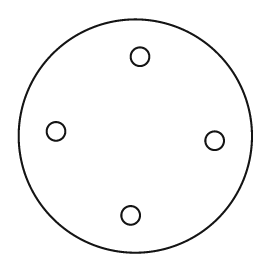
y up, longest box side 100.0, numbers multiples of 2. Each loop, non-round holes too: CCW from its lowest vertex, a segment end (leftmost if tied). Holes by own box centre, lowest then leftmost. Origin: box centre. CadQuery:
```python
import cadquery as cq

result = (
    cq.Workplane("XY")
    .moveTo(0.0, 0.0)
    .circle(50.0)
    .moveTo(-2.0, -34.0)
    .circle(4.0)
    .moveTo(34.0, -2.0)
    .circle(4.0)
    .moveTo(-34.0, 2.0)
    .circle(4.0)
    .moveTo(2.0, 34.0)
    .circle(4.0)
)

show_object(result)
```